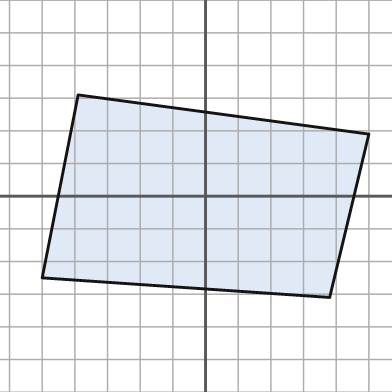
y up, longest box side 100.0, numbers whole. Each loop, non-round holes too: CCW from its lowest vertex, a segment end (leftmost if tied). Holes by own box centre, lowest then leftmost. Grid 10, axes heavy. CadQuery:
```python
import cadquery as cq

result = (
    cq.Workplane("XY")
    .moveTo(38.0, -31.0)
    .lineTo(50.0, 19.0)
    .lineTo(-39.0, 31.0)
    .lineTo(-50.0, -25.0)
    .close()
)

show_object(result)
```